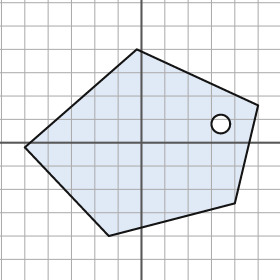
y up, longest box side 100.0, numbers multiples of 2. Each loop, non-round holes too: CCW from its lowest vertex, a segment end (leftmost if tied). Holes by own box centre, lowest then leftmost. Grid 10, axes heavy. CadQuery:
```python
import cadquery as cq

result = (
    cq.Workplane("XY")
    .moveTo(-14.0, -40.0)
    .lineTo(40.0, -26.0)
    .lineTo(50.0, 16.0)
    .lineTo(-2.0, 40.0)
    .lineTo(-50.0, -2.0)
    .close()
    .moveTo(34.0, 8.0)
    .circle(4.0)
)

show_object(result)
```